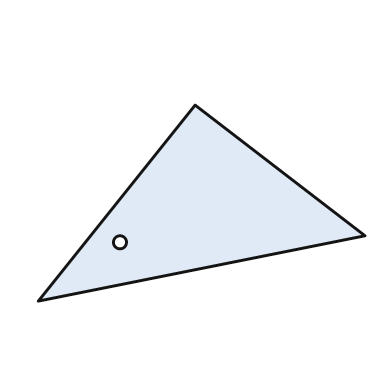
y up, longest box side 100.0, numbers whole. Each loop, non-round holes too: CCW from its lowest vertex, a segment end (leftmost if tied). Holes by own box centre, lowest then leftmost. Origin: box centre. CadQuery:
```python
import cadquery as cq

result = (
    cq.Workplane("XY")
    .moveTo(-50.0, -30.0)
    .lineTo(50.0, -10.0)
    .lineTo(-2.0, 30.0)
    .close()
    .moveTo(-25.0, -12.0)
    .circle(2.0)
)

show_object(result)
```